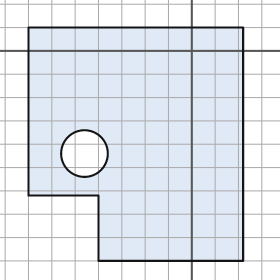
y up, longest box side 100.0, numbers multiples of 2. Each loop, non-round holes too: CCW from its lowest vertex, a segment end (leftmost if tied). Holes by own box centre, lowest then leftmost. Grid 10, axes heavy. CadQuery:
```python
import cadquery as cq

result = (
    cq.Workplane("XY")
    .moveTo(-40.0, -90.0)
    .lineTo(22.0, -90.0)
    .lineTo(22.0, 10.0)
    .lineTo(-70.0, 10.0)
    .lineTo(-70.0, -62.0)
    .lineTo(-40.0, -62.0)
    .close()
    .moveTo(-46.0, -44.0)
    .circle(10.0)
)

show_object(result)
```